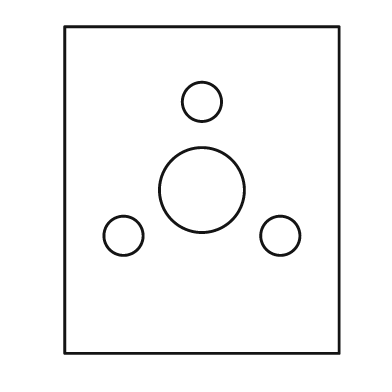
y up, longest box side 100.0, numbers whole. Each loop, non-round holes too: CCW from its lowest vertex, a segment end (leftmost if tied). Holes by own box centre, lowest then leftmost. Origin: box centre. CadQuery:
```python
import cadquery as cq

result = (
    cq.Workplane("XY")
    .moveTo(-42.0, -50.0)
    .lineTo(42.0, -50.0)
    .lineTo(42.0, 50.0)
    .lineTo(-42.0, 50.0)
    .close()
    .moveTo(-24.0, -14.0)
    .circle(6.0)
    .moveTo(24.0, -14.0)
    .circle(6.0)
    .moveTo(0.0, 0.0)
    .circle(13.0)
    .moveTo(0.0, 27.0)
    .circle(6.0)
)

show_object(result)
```